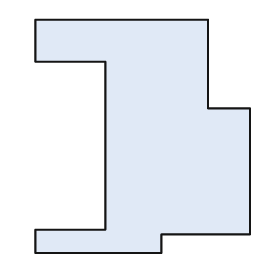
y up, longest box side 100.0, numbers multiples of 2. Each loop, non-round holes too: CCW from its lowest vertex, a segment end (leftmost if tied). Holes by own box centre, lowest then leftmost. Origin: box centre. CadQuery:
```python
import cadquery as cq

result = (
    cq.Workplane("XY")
    .moveTo(-46.0, -50.0)
    .lineTo(8.0, -50.0)
    .lineTo(8.0, -42.0)
    .lineTo(46.0, -42.0)
    .lineTo(46.0, 12.0)
    .lineTo(28.0, 12.0)
    .lineTo(28.0, 50.0)
    .lineTo(-46.0, 50.0)
    .lineTo(-46.0, 32.0)
    .lineTo(-16.0, 32.0)
    .lineTo(-16.0, -40.0)
    .lineTo(-46.0, -40.0)
    .close()
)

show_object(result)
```